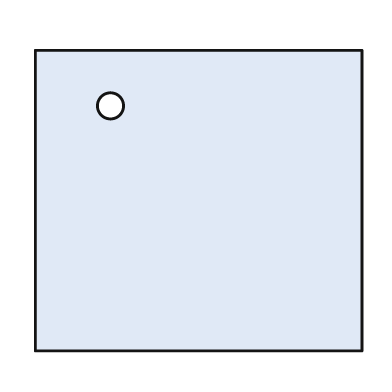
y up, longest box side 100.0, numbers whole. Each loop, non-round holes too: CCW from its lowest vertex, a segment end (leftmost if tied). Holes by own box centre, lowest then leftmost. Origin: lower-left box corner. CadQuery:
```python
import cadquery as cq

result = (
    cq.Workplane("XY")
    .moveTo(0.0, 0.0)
    .lineTo(100.0, 0.0)
    .lineTo(100.0, 92.0)
    .lineTo(0.0, 92.0)
    .close()
    .moveTo(23.0, 75.0)
    .circle(4.0)
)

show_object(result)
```